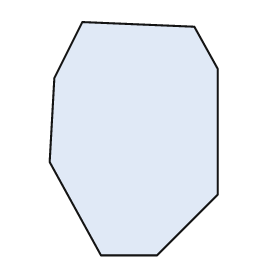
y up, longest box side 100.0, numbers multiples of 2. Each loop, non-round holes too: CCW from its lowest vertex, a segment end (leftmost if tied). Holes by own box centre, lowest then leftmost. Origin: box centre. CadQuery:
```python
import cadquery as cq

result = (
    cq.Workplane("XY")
    .moveTo(-14.0, -50.0)
    .lineTo(10.0, -50.0)
    .lineTo(36.0, -24.0)
    .lineTo(36.0, 30.0)
    .lineTo(26.0, 48.0)
    .lineTo(-22.0, 50.0)
    .lineTo(-34.0, 26.0)
    .lineTo(-36.0, -10.0)
    .close()
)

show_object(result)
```